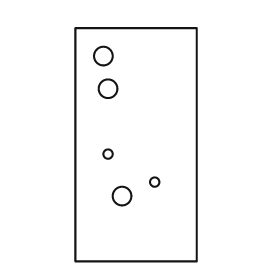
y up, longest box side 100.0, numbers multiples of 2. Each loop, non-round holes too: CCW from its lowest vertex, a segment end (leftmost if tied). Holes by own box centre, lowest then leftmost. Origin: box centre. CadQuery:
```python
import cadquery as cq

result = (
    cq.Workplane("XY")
    .moveTo(-26.0, -50.0)
    .lineTo(26.0, -50.0)
    .lineTo(26.0, 50.0)
    .lineTo(-26.0, 50.0)
    .close()
    .moveTo(-6.0, -22.0)
    .circle(4.0)
    .moveTo(8.0, -16.0)
    .circle(2.0)
    .moveTo(-12.0, -4.0)
    .circle(2.0)
    .moveTo(-12.0, 24.0)
    .circle(4.0)
    .moveTo(-14.0, 38.0)
    .circle(4.0)
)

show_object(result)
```